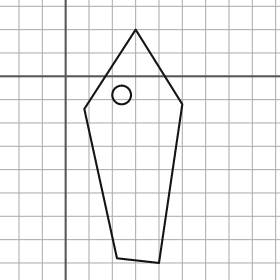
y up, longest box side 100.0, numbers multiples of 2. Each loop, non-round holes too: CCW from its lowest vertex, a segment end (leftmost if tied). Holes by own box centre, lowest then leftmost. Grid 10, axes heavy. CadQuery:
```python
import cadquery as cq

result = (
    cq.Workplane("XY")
    .moveTo(40.0, -80.0)
    .lineTo(50.0, -12.0)
    .lineTo(30.0, 20.0)
    .lineTo(8.0, -14.0)
    .lineTo(22.0, -78.0)
    .close()
    .moveTo(24.0, -8.0)
    .circle(4.0)
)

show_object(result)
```